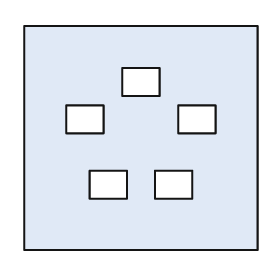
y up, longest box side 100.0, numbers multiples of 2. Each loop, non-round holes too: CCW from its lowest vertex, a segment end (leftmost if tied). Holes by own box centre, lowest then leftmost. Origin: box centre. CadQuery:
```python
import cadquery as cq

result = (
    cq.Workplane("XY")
    .moveTo(-50.0, -48.0)
    .lineTo(50.0, -48.0)
    .lineTo(50.0, 48.0)
    .lineTo(-50.0, 48.0)
    .close()
    .moveTo(-22.0, -26.0)
    .lineTo(-6.0, -26.0)
    .lineTo(-6.0, -14.0)
    .lineTo(-22.0, -14.0)
    .close()
    .moveTo(6.0, -26.0)
    .lineTo(22.0, -26.0)
    .lineTo(22.0, -14.0)
    .lineTo(6.0, -14.0)
    .close()
    .moveTo(-32.0, 2.0)
    .lineTo(-16.0, 2.0)
    .lineTo(-16.0, 14.0)
    .lineTo(-32.0, 14.0)
    .close()
    .moveTo(16.0, 2.0)
    .lineTo(32.0, 2.0)
    .lineTo(32.0, 14.0)
    .lineTo(16.0, 14.0)
    .close()
    .moveTo(-8.0, 18.0)
    .lineTo(8.0, 18.0)
    .lineTo(8.0, 30.0)
    .lineTo(-8.0, 30.0)
    .close()
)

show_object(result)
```